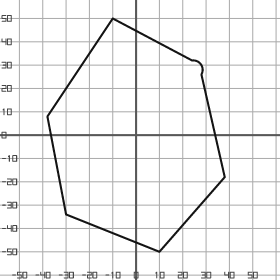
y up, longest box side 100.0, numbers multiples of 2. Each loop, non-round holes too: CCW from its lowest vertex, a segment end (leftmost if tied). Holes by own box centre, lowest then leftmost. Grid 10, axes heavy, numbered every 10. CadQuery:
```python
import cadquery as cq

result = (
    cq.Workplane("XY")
    .moveTo(10.0, -50.0)
    .lineTo(38.0, -18.0)
    .lineTo(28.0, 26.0)
    .threePointArc((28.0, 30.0), (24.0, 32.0))
    .lineTo(-10.0, 50.0)
    .lineTo(-38.0, 8.0)
    .lineTo(-30.0, -34.0)
    .close()
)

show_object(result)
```